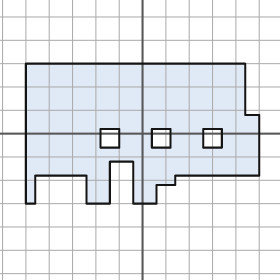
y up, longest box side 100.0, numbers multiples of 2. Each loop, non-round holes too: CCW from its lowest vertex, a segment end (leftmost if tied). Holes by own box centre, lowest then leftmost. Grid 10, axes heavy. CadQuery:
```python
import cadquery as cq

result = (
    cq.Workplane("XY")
    .moveTo(-50.0, -30.0)
    .lineTo(-46.0, -30.0)
    .lineTo(-46.0, -18.0)
    .lineTo(-24.0, -18.0)
    .lineTo(-24.0, -30.0)
    .lineTo(-14.0, -30.0)
    .lineTo(-14.0, -12.0)
    .lineTo(-4.0, -12.0)
    .lineTo(-4.0, -30.0)
    .lineTo(6.0, -30.0)
    .lineTo(6.0, -22.0)
    .lineTo(14.0, -22.0)
    .lineTo(14.0, -18.0)
    .lineTo(50.0, -18.0)
    .lineTo(50.0, 8.0)
    .lineTo(44.0, 8.0)
    .lineTo(44.0, 30.0)
    .lineTo(-50.0, 30.0)
    .close()
    .moveTo(-18.0, -6.0)
    .lineTo(-10.0, -6.0)
    .lineTo(-10.0, 2.0)
    .lineTo(-18.0, 2.0)
    .close()
    .moveTo(4.0, -6.0)
    .lineTo(12.0, -6.0)
    .lineTo(12.0, 2.0)
    .lineTo(4.0, 2.0)
    .close()
    .moveTo(26.0, -6.0)
    .lineTo(34.0, -6.0)
    .lineTo(34.0, 2.0)
    .lineTo(26.0, 2.0)
    .close()
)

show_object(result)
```